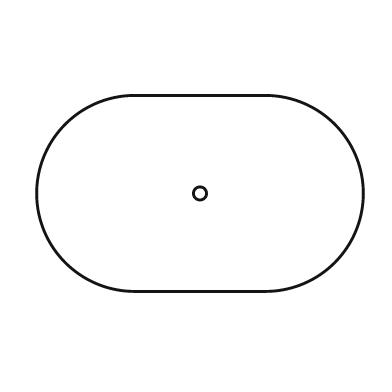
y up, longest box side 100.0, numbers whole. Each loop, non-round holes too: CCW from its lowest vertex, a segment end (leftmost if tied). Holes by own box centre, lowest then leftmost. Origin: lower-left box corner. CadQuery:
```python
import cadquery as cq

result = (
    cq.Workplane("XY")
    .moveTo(30.0, 0.0)
    .lineTo(70.0, 0.0)
    .threePointArc((100.0, 30.0), (70.0, 60.0))
    .lineTo(30.0, 60.0)
    .threePointArc((0.0, 30.0), (30.0, 0.0))
    .close()
    .moveTo(50.0, 30.0)
    .circle(2.0)
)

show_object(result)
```